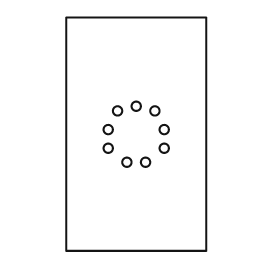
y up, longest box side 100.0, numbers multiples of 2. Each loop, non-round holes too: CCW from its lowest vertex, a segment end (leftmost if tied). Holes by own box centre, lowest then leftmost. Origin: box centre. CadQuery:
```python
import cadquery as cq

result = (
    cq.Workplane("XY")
    .moveTo(-30.0, -50.0)
    .lineTo(30.0, -50.0)
    .lineTo(30.0, 50.0)
    .lineTo(-30.0, 50.0)
    .close()
    .moveTo(-4.0, -12.0)
    .circle(2.0)
    .moveTo(4.0, -12.0)
    .circle(2.0)
    .moveTo(-12.0, -6.0)
    .circle(2.0)
    .moveTo(12.0, -6.0)
    .circle(2.0)
    .moveTo(-12.0, 2.0)
    .circle(2.0)
    .moveTo(12.0, 2.0)
    .circle(2.0)
    .moveTo(-8.0, 10.0)
    .circle(2.0)
    .moveTo(8.0, 10.0)
    .circle(2.0)
    .moveTo(0.0, 12.0)
    .circle(2.0)
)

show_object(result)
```